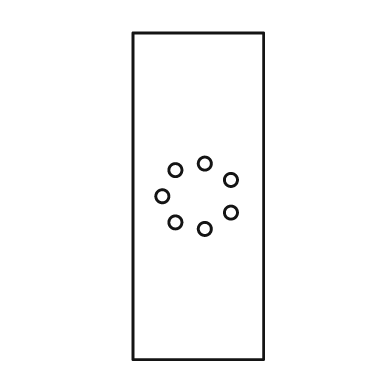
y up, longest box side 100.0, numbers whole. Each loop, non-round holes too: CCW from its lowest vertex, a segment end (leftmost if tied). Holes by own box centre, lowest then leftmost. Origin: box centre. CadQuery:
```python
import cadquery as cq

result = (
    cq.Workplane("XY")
    .moveTo(-20.0, -50.0)
    .lineTo(20.0, -50.0)
    .lineTo(20.0, 50.0)
    .lineTo(-20.0, 50.0)
    .close()
    .moveTo(2.0, -10.0)
    .circle(2.0)
    .moveTo(-7.0, -8.0)
    .circle(2.0)
    .moveTo(10.0, -5.0)
    .circle(2.0)
    .moveTo(-11.0, 0.0)
    .circle(2.0)
    .moveTo(10.0, 5.0)
    .circle(2.0)
    .moveTo(-7.0, 8.0)
    .circle(2.0)
    .moveTo(2.0, 10.0)
    .circle(2.0)
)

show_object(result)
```